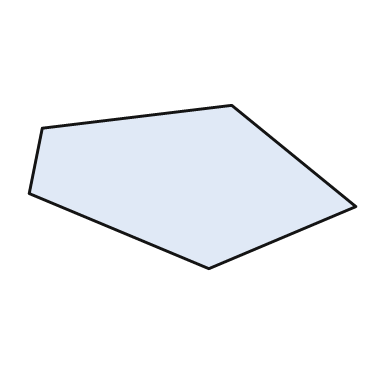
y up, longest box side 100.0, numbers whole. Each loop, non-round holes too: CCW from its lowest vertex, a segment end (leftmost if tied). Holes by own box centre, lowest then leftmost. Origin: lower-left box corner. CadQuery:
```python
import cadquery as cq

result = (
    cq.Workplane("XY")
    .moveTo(55.0, 0.0)
    .lineTo(100.0, 19.0)
    .lineTo(62.0, 50.0)
    .lineTo(4.0, 43.0)
    .lineTo(0.0, 23.0)
    .close()
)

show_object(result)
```